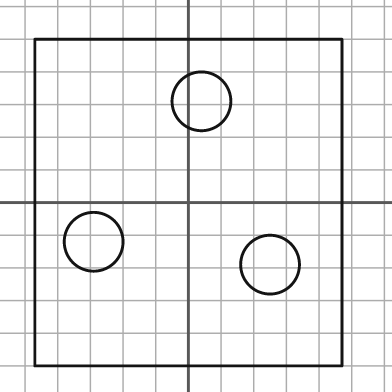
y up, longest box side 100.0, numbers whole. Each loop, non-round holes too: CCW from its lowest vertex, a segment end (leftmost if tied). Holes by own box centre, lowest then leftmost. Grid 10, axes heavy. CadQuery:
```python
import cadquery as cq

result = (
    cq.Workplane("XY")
    .moveTo(-47.0, -50.0)
    .lineTo(47.0, -50.0)
    .lineTo(47.0, 50.0)
    .lineTo(-47.0, 50.0)
    .close()
    .moveTo(25.0, -19.0)
    .circle(9.0)
    .moveTo(-29.0, -12.0)
    .circle(9.0)
    .moveTo(4.0, 31.0)
    .circle(9.0)
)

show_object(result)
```